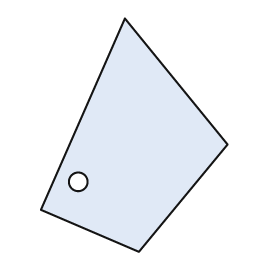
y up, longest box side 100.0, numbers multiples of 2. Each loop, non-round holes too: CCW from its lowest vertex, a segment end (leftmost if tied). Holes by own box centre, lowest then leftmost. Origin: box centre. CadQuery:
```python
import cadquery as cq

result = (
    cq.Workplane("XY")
    .moveTo(2.0, -50.0)
    .lineTo(40.0, -4.0)
    .lineTo(-4.0, 50.0)
    .lineTo(-40.0, -32.0)
    .close()
    .moveTo(-24.0, -20.0)
    .circle(4.0)
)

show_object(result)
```